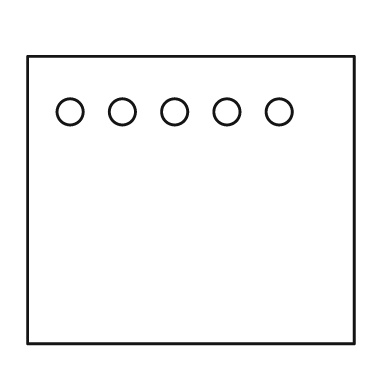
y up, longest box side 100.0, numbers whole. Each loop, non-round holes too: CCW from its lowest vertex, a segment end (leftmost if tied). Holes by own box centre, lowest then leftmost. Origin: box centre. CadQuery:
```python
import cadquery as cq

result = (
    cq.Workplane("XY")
    .moveTo(-50.0, -44.0)
    .lineTo(50.0, -44.0)
    .lineTo(50.0, 44.0)
    .lineTo(-50.0, 44.0)
    .close()
    .moveTo(-37.0, 27.0)
    .circle(4.0)
    .moveTo(-21.0, 27.0)
    .circle(4.0)
    .moveTo(-5.0, 27.0)
    .circle(4.0)
    .moveTo(11.0, 27.0)
    .circle(4.0)
    .moveTo(27.0, 27.0)
    .circle(4.0)
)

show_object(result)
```